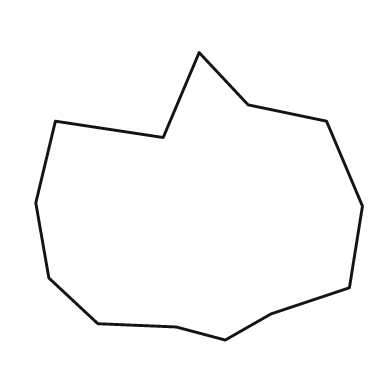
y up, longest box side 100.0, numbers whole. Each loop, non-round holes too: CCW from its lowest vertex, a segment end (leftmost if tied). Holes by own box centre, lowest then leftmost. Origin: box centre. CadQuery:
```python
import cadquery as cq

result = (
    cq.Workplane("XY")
    .moveTo(8.0, -44.0)
    .lineTo(22.0, -36.0)
    .lineTo(46.0, -28.0)
    .lineTo(50.0, -3.0)
    .lineTo(39.0, 23.0)
    .lineTo(15.0, 28.0)
    .lineTo(0.0, 44.0)
    .lineTo(-11.0, 18.0)
    .lineTo(-44.0, 23.0)
    .lineTo(-50.0, -2.0)
    .lineTo(-46.0, -25.0)
    .lineTo(-31.0, -39.0)
    .lineTo(-7.0, -40.0)
    .close()
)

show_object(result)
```